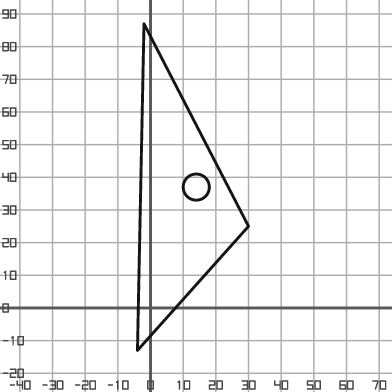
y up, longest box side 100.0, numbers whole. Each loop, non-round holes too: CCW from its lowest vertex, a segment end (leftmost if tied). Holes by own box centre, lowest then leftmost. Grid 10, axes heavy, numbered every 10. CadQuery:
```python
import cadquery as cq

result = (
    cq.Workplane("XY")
    .moveTo(-4.0, -13.0)
    .lineTo(30.0, 25.0)
    .lineTo(-2.0, 87.0)
    .close()
    .moveTo(14.0, 37.0)
    .circle(4.0)
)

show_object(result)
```